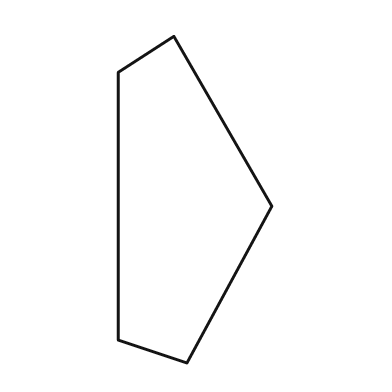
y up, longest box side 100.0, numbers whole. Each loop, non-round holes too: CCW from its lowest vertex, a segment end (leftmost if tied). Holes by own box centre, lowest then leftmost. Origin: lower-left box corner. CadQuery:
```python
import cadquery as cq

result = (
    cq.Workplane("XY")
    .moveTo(21.0, 0.0)
    .lineTo(47.0, 48.0)
    .lineTo(17.0, 100.0)
    .lineTo(0.0, 89.0)
    .lineTo(0.0, 7.0)
    .close()
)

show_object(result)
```